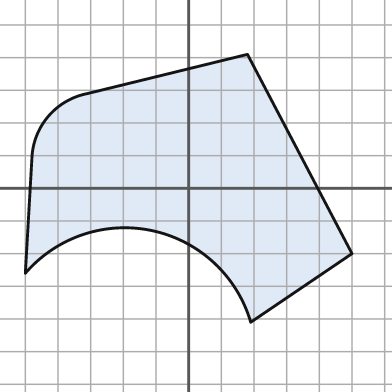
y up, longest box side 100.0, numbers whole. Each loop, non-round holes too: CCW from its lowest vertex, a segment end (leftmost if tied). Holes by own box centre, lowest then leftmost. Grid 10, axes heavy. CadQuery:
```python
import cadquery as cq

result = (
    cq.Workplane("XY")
    .moveTo(19.0, -41.0)
    .lineTo(50.0, -20.0)
    .lineTo(18.0, 41.0)
    .lineTo(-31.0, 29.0)
    .threePointArc((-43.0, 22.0), (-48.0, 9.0))
    .lineTo(-50.0, -26.0)
    .threePointArc((-11.0, -13.0), (19.0, -41.0))
    .close()
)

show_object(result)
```